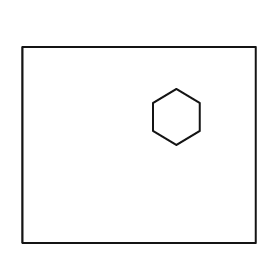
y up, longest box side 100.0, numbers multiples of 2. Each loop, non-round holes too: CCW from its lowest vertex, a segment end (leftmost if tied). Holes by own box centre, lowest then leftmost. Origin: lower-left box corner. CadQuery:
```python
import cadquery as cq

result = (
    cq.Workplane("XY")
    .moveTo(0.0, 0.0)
    .lineTo(100.0, 0.0)
    .lineTo(100.0, 84.0)
    .lineTo(0.0, 84.0)
    .close()
    .moveTo(66.0, 42.0)
    .lineTo(76.0, 48.0)
    .lineTo(76.0, 60.0)
    .lineTo(66.0, 66.0)
    .lineTo(56.0, 60.0)
    .lineTo(56.0, 48.0)
    .close()
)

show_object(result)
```